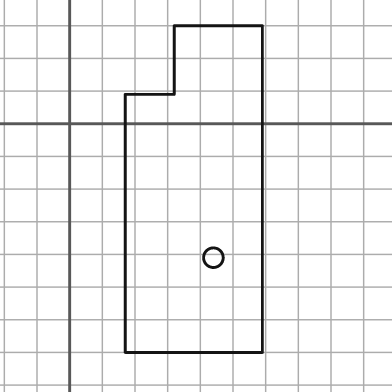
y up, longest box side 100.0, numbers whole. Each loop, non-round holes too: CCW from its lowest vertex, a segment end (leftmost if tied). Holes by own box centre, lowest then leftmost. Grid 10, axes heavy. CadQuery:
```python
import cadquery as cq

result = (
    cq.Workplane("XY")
    .moveTo(17.0, -70.0)
    .lineTo(59.0, -70.0)
    .lineTo(59.0, 30.0)
    .lineTo(32.0, 30.0)
    .lineTo(32.0, 9.0)
    .lineTo(17.0, 9.0)
    .close()
    .moveTo(44.0, -41.0)
    .circle(3.0)
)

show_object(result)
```